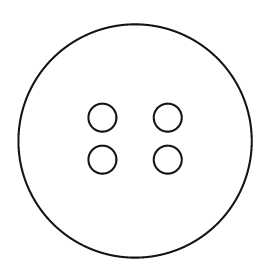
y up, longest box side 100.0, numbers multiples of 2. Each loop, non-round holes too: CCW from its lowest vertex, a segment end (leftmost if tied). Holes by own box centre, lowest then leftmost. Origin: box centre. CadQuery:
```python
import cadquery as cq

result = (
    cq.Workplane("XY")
    .moveTo(0.0, 0.0)
    .circle(50.0)
    .moveTo(-14.0, -8.0)
    .circle(6.0)
    .moveTo(14.0, -8.0)
    .circle(6.0)
    .moveTo(-14.0, 10.0)
    .circle(6.0)
    .moveTo(14.0, 10.0)
    .circle(6.0)
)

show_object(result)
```